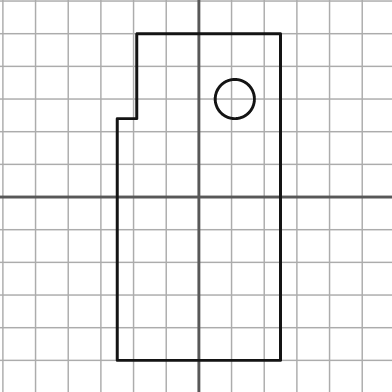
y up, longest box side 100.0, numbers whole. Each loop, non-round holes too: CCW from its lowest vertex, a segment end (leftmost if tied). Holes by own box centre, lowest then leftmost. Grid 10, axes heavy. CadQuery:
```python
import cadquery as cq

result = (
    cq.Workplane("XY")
    .moveTo(-25.0, -50.0)
    .lineTo(25.0, -50.0)
    .lineTo(25.0, 50.0)
    .lineTo(-19.0, 50.0)
    .lineTo(-19.0, 24.0)
    .lineTo(-25.0, 24.0)
    .close()
    .moveTo(11.0, 30.0)
    .circle(6.0)
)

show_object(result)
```